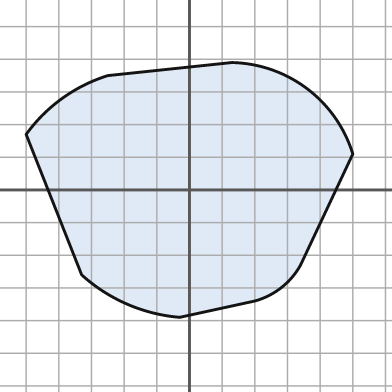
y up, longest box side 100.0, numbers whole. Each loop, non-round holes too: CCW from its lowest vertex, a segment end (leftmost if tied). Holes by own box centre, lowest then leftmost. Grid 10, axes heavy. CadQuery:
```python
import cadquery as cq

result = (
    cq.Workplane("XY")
    .moveTo(-3.0, -39.0)
    .lineTo(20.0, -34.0)
    .threePointArc((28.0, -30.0), (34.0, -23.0))
    .lineTo(50.0, 11.0)
    .threePointArc((36.0, 31.0), (13.0, 39.0))
    .lineTo(-25.0, 35.0)
    .threePointArc((-39.0, 28.0), (-50.0, 17.0))
    .lineTo(-33.0, -26.0)
    .threePointArc((-19.0, -35.0), (-3.0, -39.0))
    .close()
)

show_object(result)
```